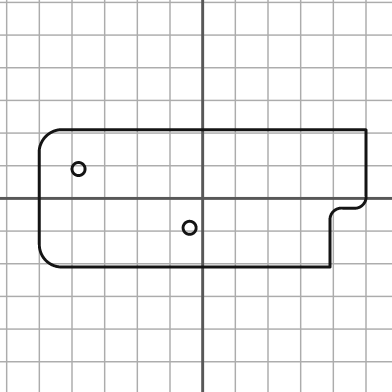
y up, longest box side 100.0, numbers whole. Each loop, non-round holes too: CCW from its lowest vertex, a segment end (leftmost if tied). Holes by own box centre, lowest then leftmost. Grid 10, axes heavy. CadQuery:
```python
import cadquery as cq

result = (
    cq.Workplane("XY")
    .moveTo(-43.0, -21.0)
    .lineTo(39.0, -21.0)
    .lineTo(39.0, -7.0)
    .threePointArc((40.0, -4.0), (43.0, -3.0))
    .lineTo(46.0, -3.0)
    .threePointArc((49.0, -2.0), (50.0, 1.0))
    .lineTo(50.0, 21.0)
    .lineTo(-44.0, 21.0)
    .threePointArc((-48.0, 19.0), (-50.0, 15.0))
    .lineTo(-50.0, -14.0)
    .threePointArc((-48.0, -19.0), (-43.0, -21.0))
    .close()
    .moveTo(-4.0, -9.0)
    .circle(2.0)
    .moveTo(-38.0, 9.0)
    .circle(2.0)
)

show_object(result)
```